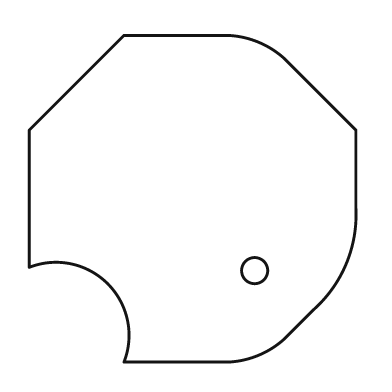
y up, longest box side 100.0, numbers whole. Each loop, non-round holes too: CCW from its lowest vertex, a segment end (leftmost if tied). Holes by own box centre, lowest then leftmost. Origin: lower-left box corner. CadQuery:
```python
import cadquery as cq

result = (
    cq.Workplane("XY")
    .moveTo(29.0, 0.0)
    .lineTo(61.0, 0.0)
    .threePointArc((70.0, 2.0), (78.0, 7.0))
    .lineTo(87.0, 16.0)
    .threePointArc((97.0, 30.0), (100.0, 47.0))
    .lineTo(100.0, 71.0)
    .lineTo(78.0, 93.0)
    .threePointArc((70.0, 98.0), (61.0, 100.0))
    .lineTo(29.0, 100.0)
    .lineTo(0.0, 71.0)
    .lineTo(0.0, 29.0)
    .threePointArc((24.0, 24.0), (29.0, 0.0))
    .close()
    .moveTo(69.0, 28.0)
    .circle(4.0)
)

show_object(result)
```